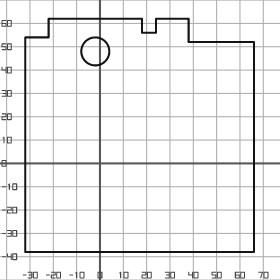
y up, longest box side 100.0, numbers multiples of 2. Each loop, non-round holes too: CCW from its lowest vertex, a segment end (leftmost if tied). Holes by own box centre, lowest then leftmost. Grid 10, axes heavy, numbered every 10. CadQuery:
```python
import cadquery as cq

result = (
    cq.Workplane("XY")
    .moveTo(-32.0, -38.0)
    .lineTo(66.0, -38.0)
    .lineTo(66.0, 52.0)
    .lineTo(38.0, 52.0)
    .lineTo(38.0, 62.0)
    .lineTo(24.0, 62.0)
    .lineTo(24.0, 56.0)
    .lineTo(18.0, 56.0)
    .lineTo(18.0, 62.0)
    .lineTo(-22.0, 62.0)
    .lineTo(-22.0, 54.0)
    .lineTo(-32.0, 54.0)
    .close()
    .moveTo(-2.0, 48.0)
    .circle(6.0)
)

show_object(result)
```